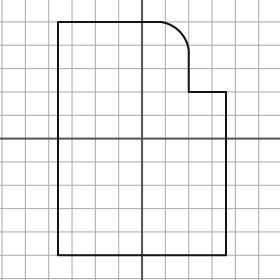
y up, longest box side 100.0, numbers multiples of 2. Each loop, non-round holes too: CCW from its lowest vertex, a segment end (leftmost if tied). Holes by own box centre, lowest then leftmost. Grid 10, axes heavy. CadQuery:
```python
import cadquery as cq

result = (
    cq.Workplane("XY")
    .moveTo(-36.0, -50.0)
    .lineTo(36.0, -50.0)
    .lineTo(36.0, 20.0)
    .lineTo(20.0, 20.0)
    .lineTo(20.0, 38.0)
    .threePointArc((16.0, 46.0), (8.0, 50.0))
    .lineTo(-36.0, 50.0)
    .close()
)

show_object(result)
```